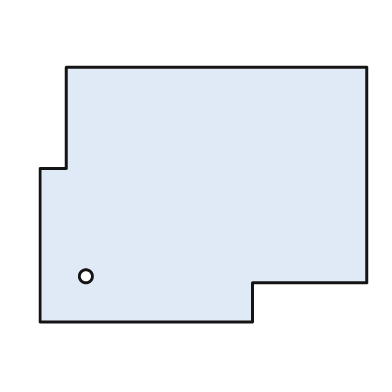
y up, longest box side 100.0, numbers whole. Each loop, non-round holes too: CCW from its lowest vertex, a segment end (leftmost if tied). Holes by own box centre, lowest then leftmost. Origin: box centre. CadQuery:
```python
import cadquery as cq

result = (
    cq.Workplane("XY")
    .moveTo(-50.0, -39.0)
    .lineTo(15.0, -39.0)
    .lineTo(15.0, -27.0)
    .lineTo(50.0, -27.0)
    .lineTo(50.0, 39.0)
    .lineTo(-42.0, 39.0)
    .lineTo(-42.0, 8.0)
    .lineTo(-50.0, 8.0)
    .close()
    .moveTo(-36.0, -25.0)
    .circle(2.0)
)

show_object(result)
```